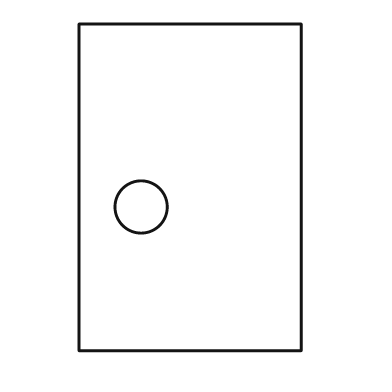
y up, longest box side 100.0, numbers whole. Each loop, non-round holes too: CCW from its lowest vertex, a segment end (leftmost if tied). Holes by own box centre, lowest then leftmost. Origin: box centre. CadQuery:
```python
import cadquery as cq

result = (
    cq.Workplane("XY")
    .moveTo(-34.0, -50.0)
    .lineTo(34.0, -50.0)
    .lineTo(34.0, 50.0)
    .lineTo(-34.0, 50.0)
    .close()
    .moveTo(-15.0, -6.0)
    .circle(8.0)
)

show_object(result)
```